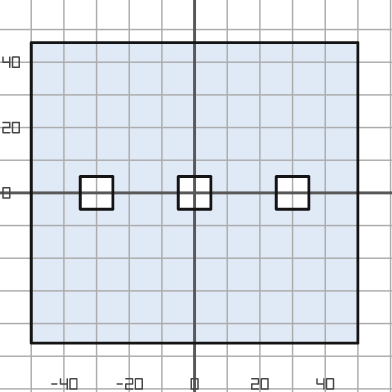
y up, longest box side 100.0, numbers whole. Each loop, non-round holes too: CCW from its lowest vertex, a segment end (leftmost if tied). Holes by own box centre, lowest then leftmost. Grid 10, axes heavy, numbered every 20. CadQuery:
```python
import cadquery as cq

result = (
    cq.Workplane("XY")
    .moveTo(-50.0, -46.0)
    .lineTo(50.0, -46.0)
    .lineTo(50.0, 46.0)
    .lineTo(-50.0, 46.0)
    .close()
    .moveTo(-35.0, -5.0)
    .lineTo(-25.0, -5.0)
    .lineTo(-25.0, 5.0)
    .lineTo(-35.0, 5.0)
    .close()
    .moveTo(-5.0, -5.0)
    .lineTo(5.0, -5.0)
    .lineTo(5.0, 5.0)
    .lineTo(-5.0, 5.0)
    .close()
    .moveTo(25.0, -5.0)
    .lineTo(35.0, -5.0)
    .lineTo(35.0, 5.0)
    .lineTo(25.0, 5.0)
    .close()
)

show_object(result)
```